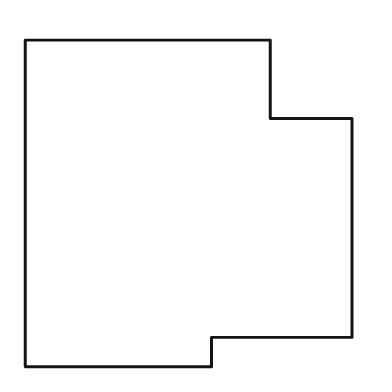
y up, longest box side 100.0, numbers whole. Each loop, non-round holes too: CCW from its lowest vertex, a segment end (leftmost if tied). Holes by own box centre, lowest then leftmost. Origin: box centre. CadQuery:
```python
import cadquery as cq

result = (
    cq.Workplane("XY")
    .moveTo(-50.0, -50.0)
    .lineTo(7.0, -50.0)
    .lineTo(7.0, -41.0)
    .lineTo(50.0, -41.0)
    .lineTo(50.0, 26.0)
    .lineTo(25.0, 26.0)
    .lineTo(25.0, 50.0)
    .lineTo(-50.0, 50.0)
    .close()
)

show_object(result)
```